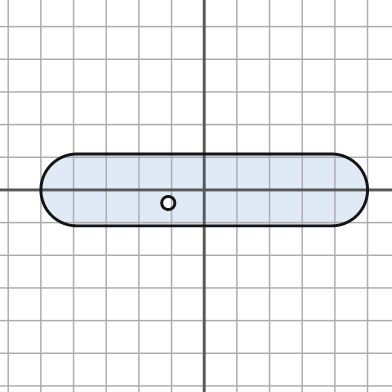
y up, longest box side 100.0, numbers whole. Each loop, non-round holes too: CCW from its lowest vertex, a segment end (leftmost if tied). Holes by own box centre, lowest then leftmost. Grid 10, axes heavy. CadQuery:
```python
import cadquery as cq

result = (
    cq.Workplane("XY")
    .moveTo(-39.0, -11.0)
    .lineTo(39.0, -11.0)
    .threePointArc((50.0, 0.0), (39.0, 11.0))
    .lineTo(-39.0, 11.0)
    .threePointArc((-50.0, 0.0), (-39.0, -11.0))
    .close()
    .moveTo(-11.0, -4.0)
    .circle(2.0)
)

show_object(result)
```